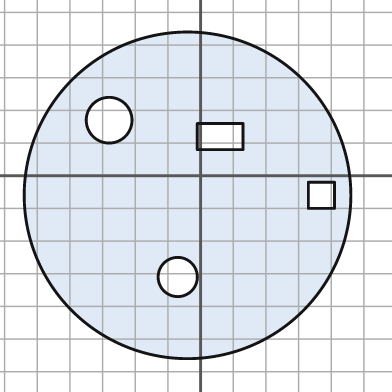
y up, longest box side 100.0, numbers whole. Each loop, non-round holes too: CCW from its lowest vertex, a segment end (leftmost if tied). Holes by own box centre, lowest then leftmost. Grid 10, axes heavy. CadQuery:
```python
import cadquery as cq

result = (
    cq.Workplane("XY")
    .moveTo(-4.0, -6.0)
    .circle(50.0)
    .moveTo(-7.0, -31.0)
    .circle(6.0)
    .moveTo(33.0, -10.0)
    .lineTo(41.0, -10.0)
    .lineTo(41.0, -2.0)
    .lineTo(33.0, -2.0)
    .close()
    .moveTo(-1.0, 8.0)
    .lineTo(13.0, 8.0)
    .lineTo(13.0, 16.0)
    .lineTo(-1.0, 16.0)
    .close()
    .moveTo(-28.0, 17.0)
    .circle(7.0)
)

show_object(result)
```